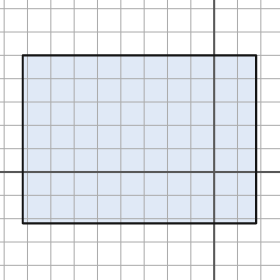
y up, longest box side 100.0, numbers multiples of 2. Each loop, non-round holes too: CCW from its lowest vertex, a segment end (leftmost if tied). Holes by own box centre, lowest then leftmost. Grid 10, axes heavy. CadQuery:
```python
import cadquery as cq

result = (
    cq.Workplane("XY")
    .moveTo(-82.0, -22.0)
    .lineTo(18.0, -22.0)
    .lineTo(18.0, 50.0)
    .lineTo(-82.0, 50.0)
    .close()
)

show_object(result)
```